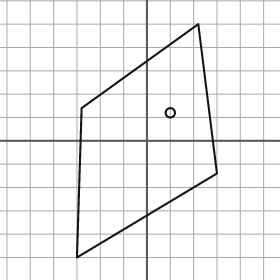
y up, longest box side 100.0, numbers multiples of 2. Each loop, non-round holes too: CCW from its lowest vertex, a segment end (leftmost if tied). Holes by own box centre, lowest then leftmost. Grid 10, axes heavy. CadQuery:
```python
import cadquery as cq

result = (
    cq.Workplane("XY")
    .moveTo(-30.0, -50.0)
    .lineTo(30.0, -14.0)
    .lineTo(22.0, 50.0)
    .lineTo(-28.0, 14.0)
    .close()
    .moveTo(10.0, 12.0)
    .circle(2.0)
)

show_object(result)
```